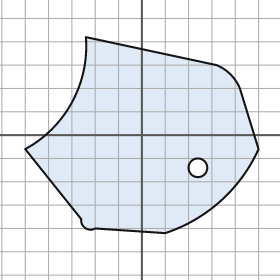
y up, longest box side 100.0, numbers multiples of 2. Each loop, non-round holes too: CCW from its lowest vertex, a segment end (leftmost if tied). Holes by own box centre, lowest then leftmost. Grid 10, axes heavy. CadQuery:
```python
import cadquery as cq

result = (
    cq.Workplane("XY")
    .moveTo(10.0, -42.0)
    .threePointArc((34.0, -28.0), (50.0, -6.0))
    .lineTo(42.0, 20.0)
    .threePointArc((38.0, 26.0), (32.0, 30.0))
    .lineTo(-24.0, 42.0)
    .threePointArc((-30.0, 14.0), (-50.0, -6.0))
    .lineTo(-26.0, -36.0)
    .threePointArc((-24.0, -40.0), (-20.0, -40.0))
    .close()
    .moveTo(24.0, -14.0)
    .circle(4.0)
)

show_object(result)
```